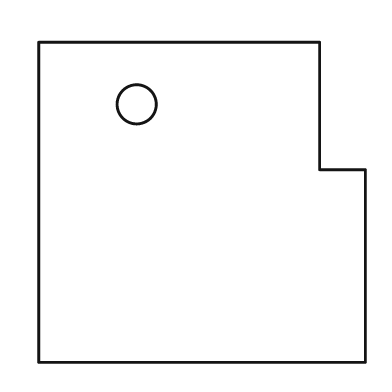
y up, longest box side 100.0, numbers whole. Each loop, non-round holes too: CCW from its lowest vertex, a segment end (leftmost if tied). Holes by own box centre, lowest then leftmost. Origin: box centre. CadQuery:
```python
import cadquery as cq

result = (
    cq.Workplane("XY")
    .moveTo(-50.0, -49.0)
    .lineTo(50.0, -49.0)
    .lineTo(50.0, 10.0)
    .lineTo(36.0, 10.0)
    .lineTo(36.0, 49.0)
    .lineTo(-50.0, 49.0)
    .close()
    .moveTo(-20.0, 30.0)
    .circle(6.0)
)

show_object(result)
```